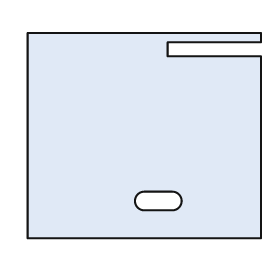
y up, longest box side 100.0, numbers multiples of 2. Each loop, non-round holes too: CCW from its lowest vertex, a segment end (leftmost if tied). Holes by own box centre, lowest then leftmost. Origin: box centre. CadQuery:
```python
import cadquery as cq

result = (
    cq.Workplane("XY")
    .moveTo(-50.0, -44.0)
    .lineTo(50.0, -44.0)
    .lineTo(50.0, 34.0)
    .lineTo(10.0, 34.0)
    .lineTo(10.0, 40.0)
    .lineTo(50.0, 40.0)
    .lineTo(50.0, 44.0)
    .lineTo(-50.0, 44.0)
    .close()
    .moveTo(0.0, -32.0)
    .lineTo(12.0, -32.0)
    .threePointArc((16.0, -28.0), (12.0, -24.0))
    .lineTo(0.0, -24.0)
    .threePointArc((-4.0, -28.0), (0.0, -32.0))
    .close()
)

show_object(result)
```